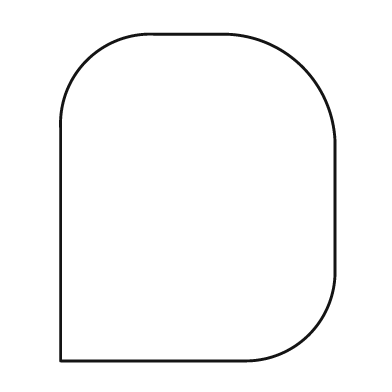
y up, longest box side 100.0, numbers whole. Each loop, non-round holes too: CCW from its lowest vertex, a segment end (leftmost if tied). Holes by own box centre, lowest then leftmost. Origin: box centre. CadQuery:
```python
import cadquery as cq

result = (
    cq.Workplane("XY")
    .moveTo(-42.0, -50.0)
    .lineTo(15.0, -50.0)
    .threePointArc((34.0, -42.0), (42.0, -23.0))
    .lineTo(42.0, 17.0)
    .threePointArc((32.0, 40.0), (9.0, 50.0))
    .lineTo(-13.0, 50.0)
    .threePointArc((-34.0, 42.0), (-42.0, 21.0))
    .close()
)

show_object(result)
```